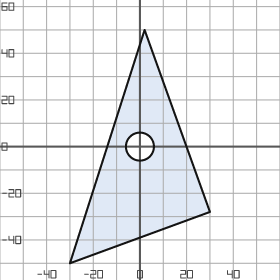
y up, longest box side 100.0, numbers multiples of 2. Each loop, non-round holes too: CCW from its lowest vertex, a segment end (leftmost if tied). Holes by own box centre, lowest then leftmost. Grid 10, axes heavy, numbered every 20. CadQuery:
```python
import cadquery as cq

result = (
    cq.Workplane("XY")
    .moveTo(-30.0, -50.0)
    .lineTo(30.0, -28.0)
    .lineTo(2.0, 50.0)
    .close()
    .moveTo(0.0, 0.0)
    .circle(6.0)
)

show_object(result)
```